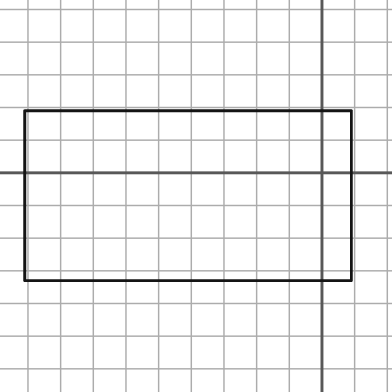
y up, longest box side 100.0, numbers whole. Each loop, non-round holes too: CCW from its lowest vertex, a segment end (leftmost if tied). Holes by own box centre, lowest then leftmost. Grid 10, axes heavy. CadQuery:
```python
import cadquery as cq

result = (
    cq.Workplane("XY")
    .moveTo(-91.0, -33.0)
    .lineTo(9.0, -33.0)
    .lineTo(9.0, 19.0)
    .lineTo(-91.0, 19.0)
    .close()
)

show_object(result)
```